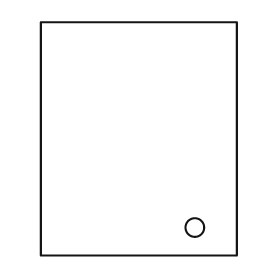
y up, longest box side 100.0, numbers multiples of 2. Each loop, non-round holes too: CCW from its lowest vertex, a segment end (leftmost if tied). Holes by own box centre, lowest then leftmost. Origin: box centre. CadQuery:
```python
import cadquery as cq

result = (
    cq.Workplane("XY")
    .moveTo(-42.0, -50.0)
    .lineTo(42.0, -50.0)
    .lineTo(42.0, 50.0)
    .lineTo(-42.0, 50.0)
    .close()
    .moveTo(24.0, -38.0)
    .circle(4.0)
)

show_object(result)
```